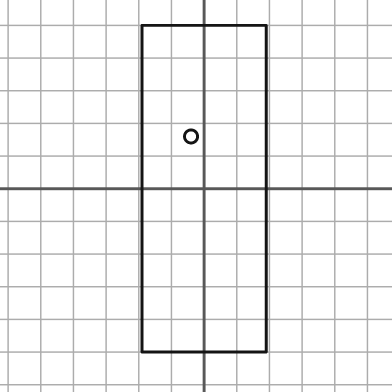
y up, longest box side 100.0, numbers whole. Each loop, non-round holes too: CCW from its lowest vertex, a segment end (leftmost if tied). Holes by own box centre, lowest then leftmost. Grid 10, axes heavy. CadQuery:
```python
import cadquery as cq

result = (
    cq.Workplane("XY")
    .moveTo(-19.0, -50.0)
    .lineTo(19.0, -50.0)
    .lineTo(19.0, 50.0)
    .lineTo(-19.0, 50.0)
    .close()
    .moveTo(-4.0, 16.0)
    .circle(2.0)
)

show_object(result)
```